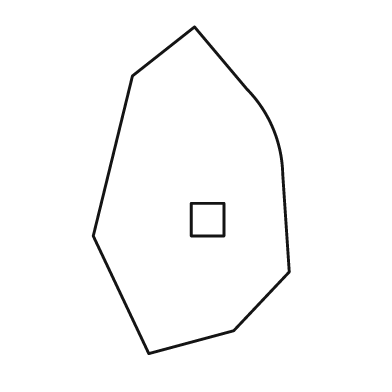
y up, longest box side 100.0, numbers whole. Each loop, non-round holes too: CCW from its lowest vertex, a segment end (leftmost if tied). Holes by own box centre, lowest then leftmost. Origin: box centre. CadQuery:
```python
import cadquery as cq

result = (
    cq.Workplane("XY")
    .moveTo(-13.0, -50.0)
    .lineTo(13.0, -43.0)
    .lineTo(30.0, -25.0)
    .lineTo(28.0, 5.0)
    .threePointArc((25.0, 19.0), (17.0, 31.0))
    .lineTo(1.0, 50.0)
    .lineTo(-18.0, 35.0)
    .lineTo(-30.0, -14.0)
    .close()
    .moveTo(0.0, -14.0)
    .lineTo(10.0, -14.0)
    .lineTo(10.0, -4.0)
    .lineTo(0.0, -4.0)
    .close()
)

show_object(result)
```